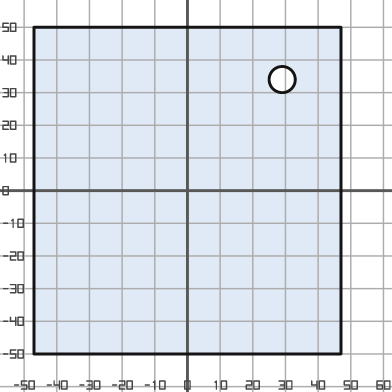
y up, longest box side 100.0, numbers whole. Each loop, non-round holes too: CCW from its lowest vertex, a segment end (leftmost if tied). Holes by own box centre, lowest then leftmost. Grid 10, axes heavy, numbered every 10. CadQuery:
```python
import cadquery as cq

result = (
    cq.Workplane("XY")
    .moveTo(-47.0, -50.0)
    .lineTo(47.0, -50.0)
    .lineTo(47.0, 50.0)
    .lineTo(-47.0, 50.0)
    .close()
    .moveTo(29.0, 34.0)
    .circle(4.0)
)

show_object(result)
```